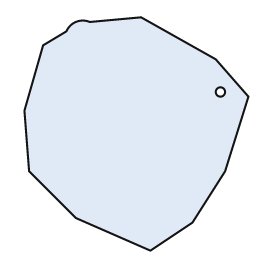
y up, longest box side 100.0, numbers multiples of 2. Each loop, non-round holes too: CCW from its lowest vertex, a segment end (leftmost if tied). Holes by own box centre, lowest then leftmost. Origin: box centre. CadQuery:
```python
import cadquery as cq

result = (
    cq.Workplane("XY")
    .moveTo(6.0, -50.0)
    .lineTo(24.0, -38.0)
    .lineTo(38.0, -16.0)
    .lineTo(48.0, 16.0)
    .lineTo(34.0, 32.0)
    .lineTo(2.0, 50.0)
    .lineTo(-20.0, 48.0)
    .threePointArc((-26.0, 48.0), (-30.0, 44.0))
    .lineTo(-40.0, 38.0)
    .lineTo(-48.0, 10.0)
    .lineTo(-46.0, -16.0)
    .lineTo(-26.0, -36.0)
    .close()
    .moveTo(36.0, 18.0)
    .circle(2.0)
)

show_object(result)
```